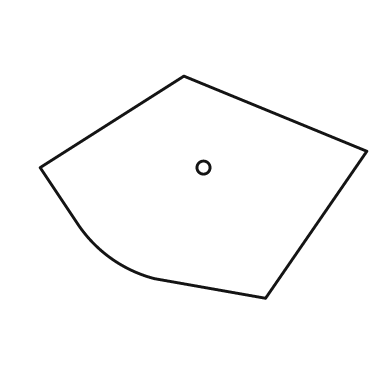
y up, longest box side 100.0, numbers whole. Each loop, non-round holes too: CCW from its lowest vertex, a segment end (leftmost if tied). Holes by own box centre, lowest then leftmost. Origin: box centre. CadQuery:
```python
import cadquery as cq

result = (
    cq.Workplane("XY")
    .moveTo(19.0, -34.0)
    .lineTo(50.0, 11.0)
    .lineTo(-6.0, 34.0)
    .lineTo(-50.0, 6.0)
    .lineTo(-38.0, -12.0)
    .threePointArc((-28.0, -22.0), (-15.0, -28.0))
    .close()
    .moveTo(0.0, 6.0)
    .circle(2.0)
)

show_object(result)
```